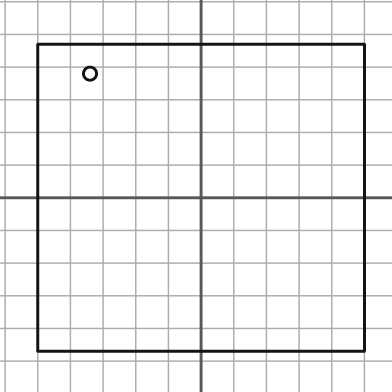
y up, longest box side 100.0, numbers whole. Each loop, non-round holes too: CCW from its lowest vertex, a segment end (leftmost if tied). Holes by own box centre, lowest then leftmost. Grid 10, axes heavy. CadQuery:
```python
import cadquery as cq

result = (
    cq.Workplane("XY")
    .moveTo(-50.0, -47.0)
    .lineTo(50.0, -47.0)
    .lineTo(50.0, 47.0)
    .lineTo(-50.0, 47.0)
    .close()
    .moveTo(-34.0, 38.0)
    .circle(2.0)
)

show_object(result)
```